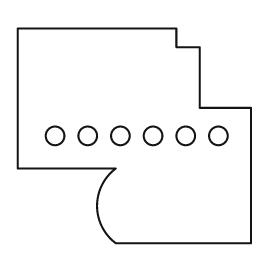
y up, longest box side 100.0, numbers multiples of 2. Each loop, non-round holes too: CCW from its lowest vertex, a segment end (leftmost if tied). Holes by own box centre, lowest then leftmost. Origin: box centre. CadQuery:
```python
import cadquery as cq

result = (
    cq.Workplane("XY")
    .moveTo(-8.0, -46.0)
    .lineTo(50.0, -46.0)
    .lineTo(50.0, 12.0)
    .lineTo(28.0, 12.0)
    .lineTo(28.0, 38.0)
    .lineTo(18.0, 38.0)
    .lineTo(18.0, 46.0)
    .lineTo(-50.0, 46.0)
    .lineTo(-50.0, -14.0)
    .lineTo(-8.0, -14.0)
    .threePointArc((-16.0, -30.0), (-8.0, -46.0))
    .close()
    .moveTo(-34.0, 0.0)
    .circle(4.0)
    .moveTo(-20.0, 0.0)
    .circle(4.0)
    .moveTo(-6.0, 0.0)
    .circle(4.0)
    .moveTo(8.0, 0.0)
    .circle(4.0)
    .moveTo(22.0, 0.0)
    .circle(4.0)
    .moveTo(36.0, 0.0)
    .circle(4.0)
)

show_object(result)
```